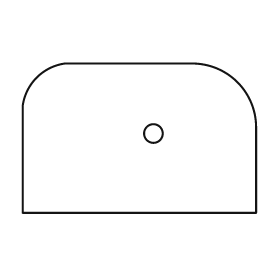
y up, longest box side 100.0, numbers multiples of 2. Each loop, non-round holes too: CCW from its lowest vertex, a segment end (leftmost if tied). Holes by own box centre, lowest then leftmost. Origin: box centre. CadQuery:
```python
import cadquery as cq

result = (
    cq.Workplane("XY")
    .moveTo(-50.0, -32.0)
    .lineTo(50.0, -32.0)
    .lineTo(50.0, 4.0)
    .threePointArc((42.0, 24.0), (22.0, 32.0))
    .lineTo(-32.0, 32.0)
    .threePointArc((-44.0, 26.0), (-50.0, 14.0))
    .close()
    .moveTo(6.0, 2.0)
    .circle(4.0)
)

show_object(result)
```